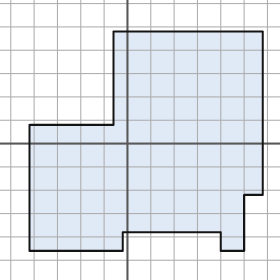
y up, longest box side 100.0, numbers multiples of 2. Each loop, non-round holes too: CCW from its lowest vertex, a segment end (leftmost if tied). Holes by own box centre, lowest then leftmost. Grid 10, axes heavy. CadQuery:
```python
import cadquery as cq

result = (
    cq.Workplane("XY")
    .moveTo(-42.0, -46.0)
    .lineTo(-2.0, -46.0)
    .lineTo(-2.0, -38.0)
    .lineTo(40.0, -38.0)
    .lineTo(40.0, -46.0)
    .lineTo(50.0, -46.0)
    .lineTo(50.0, -22.0)
    .lineTo(58.0, -22.0)
    .lineTo(58.0, 48.0)
    .lineTo(-6.0, 48.0)
    .lineTo(-6.0, 8.0)
    .lineTo(-42.0, 8.0)
    .close()
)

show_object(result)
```